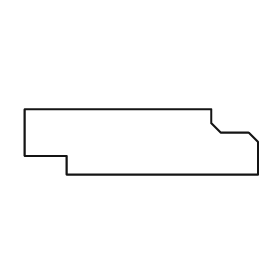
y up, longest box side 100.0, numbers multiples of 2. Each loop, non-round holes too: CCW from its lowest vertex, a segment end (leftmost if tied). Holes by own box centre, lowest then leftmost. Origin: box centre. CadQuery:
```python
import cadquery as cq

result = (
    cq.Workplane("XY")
    .moveTo(-32.0, -14.0)
    .lineTo(50.0, -14.0)
    .lineTo(50.0, 0.0)
    .lineTo(46.0, 4.0)
    .lineTo(34.0, 4.0)
    .lineTo(30.0, 8.0)
    .lineTo(30.0, 14.0)
    .lineTo(-50.0, 14.0)
    .lineTo(-50.0, -6.0)
    .lineTo(-32.0, -6.0)
    .close()
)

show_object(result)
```